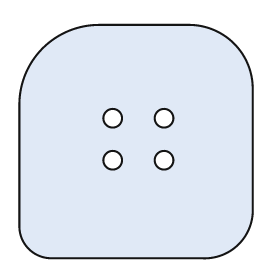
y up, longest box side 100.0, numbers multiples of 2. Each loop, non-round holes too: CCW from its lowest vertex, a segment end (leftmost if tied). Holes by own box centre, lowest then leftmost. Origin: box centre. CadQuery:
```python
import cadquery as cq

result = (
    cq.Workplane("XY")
    .moveTo(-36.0, -50.0)
    .lineTo(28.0, -50.0)
    .threePointArc((44.0, -44.0), (50.0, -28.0))
    .lineTo(50.0, 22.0)
    .threePointArc((42.0, 42.0), (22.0, 50.0))
    .lineTo(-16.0, 50.0)
    .threePointArc((-40.0, 40.0), (-50.0, 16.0))
    .lineTo(-50.0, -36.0)
    .threePointArc((-46.0, -46.0), (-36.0, -50.0))
    .close()
    .moveTo(-10.0, -8.0)
    .circle(4.0)
    .moveTo(12.0, -8.0)
    .circle(4.0)
    .moveTo(-10.0, 10.0)
    .circle(4.0)
    .moveTo(12.0, 10.0)
    .circle(4.0)
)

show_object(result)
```